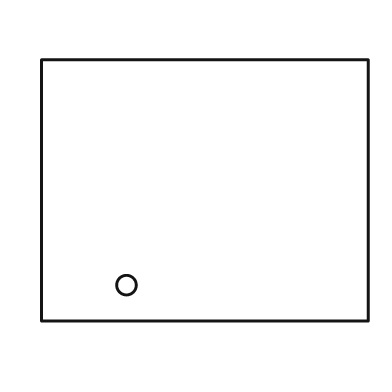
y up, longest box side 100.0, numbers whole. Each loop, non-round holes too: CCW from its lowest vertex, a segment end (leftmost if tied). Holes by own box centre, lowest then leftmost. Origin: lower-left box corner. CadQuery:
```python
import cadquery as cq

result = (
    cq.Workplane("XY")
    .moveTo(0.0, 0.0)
    .lineTo(100.0, 0.0)
    .lineTo(100.0, 80.0)
    .lineTo(0.0, 80.0)
    .close()
    .moveTo(26.0, 11.0)
    .circle(3.0)
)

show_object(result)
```